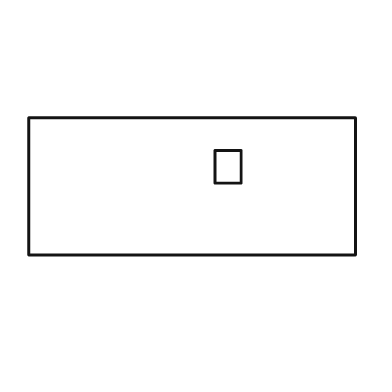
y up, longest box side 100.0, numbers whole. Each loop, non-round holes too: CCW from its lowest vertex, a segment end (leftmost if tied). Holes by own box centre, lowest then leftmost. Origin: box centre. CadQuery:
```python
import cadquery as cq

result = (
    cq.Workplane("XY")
    .moveTo(-50.0, -21.0)
    .lineTo(50.0, -21.0)
    .lineTo(50.0, 21.0)
    .lineTo(-50.0, 21.0)
    .close()
    .moveTo(7.0, 1.0)
    .lineTo(15.0, 1.0)
    .lineTo(15.0, 11.0)
    .lineTo(7.0, 11.0)
    .close()
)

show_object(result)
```